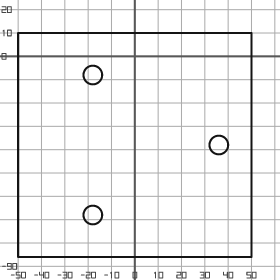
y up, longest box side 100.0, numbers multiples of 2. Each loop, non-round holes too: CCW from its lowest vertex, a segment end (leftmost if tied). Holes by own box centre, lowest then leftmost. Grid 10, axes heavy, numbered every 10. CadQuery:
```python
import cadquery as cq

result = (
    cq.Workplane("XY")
    .moveTo(-50.0, -86.0)
    .lineTo(50.0, -86.0)
    .lineTo(50.0, 10.0)
    .lineTo(-50.0, 10.0)
    .close()
    .moveTo(-18.0, -68.0)
    .circle(4.0)
    .moveTo(36.0, -38.0)
    .circle(4.0)
    .moveTo(-18.0, -8.0)
    .circle(4.0)
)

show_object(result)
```